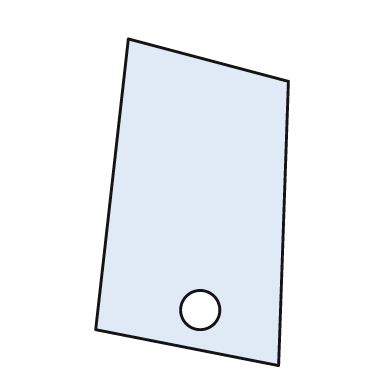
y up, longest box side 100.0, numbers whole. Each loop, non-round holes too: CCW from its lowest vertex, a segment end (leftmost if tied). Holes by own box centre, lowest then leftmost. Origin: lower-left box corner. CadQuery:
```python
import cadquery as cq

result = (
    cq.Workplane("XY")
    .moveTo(56.0, 0.0)
    .lineTo(59.0, 87.0)
    .lineTo(10.0, 100.0)
    .lineTo(0.0, 11.0)
    .close()
    .moveTo(32.0, 17.0)
    .circle(6.0)
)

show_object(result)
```